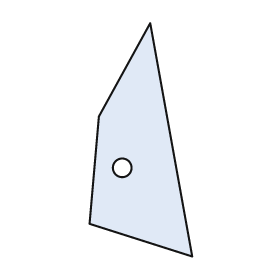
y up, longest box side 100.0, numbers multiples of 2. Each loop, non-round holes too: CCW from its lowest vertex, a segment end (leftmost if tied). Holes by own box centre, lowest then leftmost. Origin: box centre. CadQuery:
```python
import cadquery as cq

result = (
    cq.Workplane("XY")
    .moveTo(22.0, -50.0)
    .lineTo(4.0, 50.0)
    .lineTo(-18.0, 10.0)
    .lineTo(-22.0, -36.0)
    .close()
    .moveTo(-8.0, -12.0)
    .circle(4.0)
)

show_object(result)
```